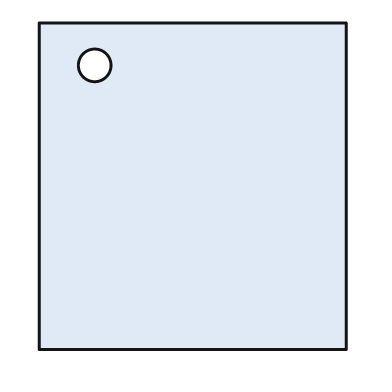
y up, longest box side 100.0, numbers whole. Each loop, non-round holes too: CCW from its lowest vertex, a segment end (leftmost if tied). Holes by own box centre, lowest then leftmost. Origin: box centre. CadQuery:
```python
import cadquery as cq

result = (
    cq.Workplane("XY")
    .moveTo(-47.0, -50.0)
    .lineTo(47.0, -50.0)
    .lineTo(47.0, 50.0)
    .lineTo(-47.0, 50.0)
    .close()
    .moveTo(-30.0, 37.0)
    .circle(5.0)
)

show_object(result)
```